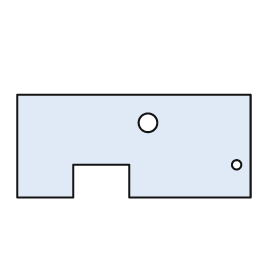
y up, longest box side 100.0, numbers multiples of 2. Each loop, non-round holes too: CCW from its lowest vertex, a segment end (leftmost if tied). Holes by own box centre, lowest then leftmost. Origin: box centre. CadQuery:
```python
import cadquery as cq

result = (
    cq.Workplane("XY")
    .moveTo(-50.0, -22.0)
    .lineTo(-26.0, -22.0)
    .lineTo(-26.0, -8.0)
    .lineTo(-2.0, -8.0)
    .lineTo(-2.0, -22.0)
    .lineTo(50.0, -22.0)
    .lineTo(50.0, 22.0)
    .lineTo(-50.0, 22.0)
    .close()
    .moveTo(44.0, -8.0)
    .circle(2.0)
    .moveTo(6.0, 10.0)
    .circle(4.0)
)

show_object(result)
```